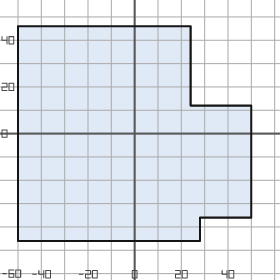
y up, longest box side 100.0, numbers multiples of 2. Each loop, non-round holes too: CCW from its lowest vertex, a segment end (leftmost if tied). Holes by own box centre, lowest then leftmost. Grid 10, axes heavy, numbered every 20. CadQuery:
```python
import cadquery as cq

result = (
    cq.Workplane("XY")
    .moveTo(-50.0, -46.0)
    .lineTo(28.0, -46.0)
    .lineTo(28.0, -36.0)
    .lineTo(50.0, -36.0)
    .lineTo(50.0, 12.0)
    .lineTo(24.0, 12.0)
    .lineTo(24.0, 46.0)
    .lineTo(-50.0, 46.0)
    .close()
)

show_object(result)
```